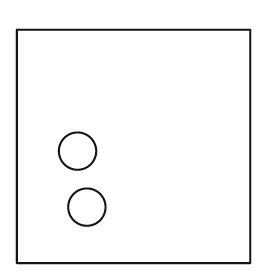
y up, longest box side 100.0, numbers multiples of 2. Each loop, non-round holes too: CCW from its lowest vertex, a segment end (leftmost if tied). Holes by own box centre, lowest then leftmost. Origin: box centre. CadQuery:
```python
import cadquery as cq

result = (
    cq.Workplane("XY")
    .moveTo(-50.0, -50.0)
    .lineTo(50.0, -50.0)
    .lineTo(50.0, 50.0)
    .lineTo(-50.0, 50.0)
    .close()
    .moveTo(-20.0, -26.0)
    .circle(8.0)
    .moveTo(-24.0, -2.0)
    .circle(8.0)
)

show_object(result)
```